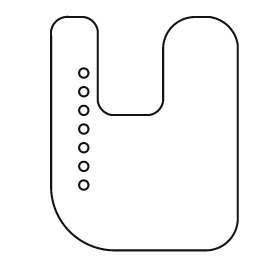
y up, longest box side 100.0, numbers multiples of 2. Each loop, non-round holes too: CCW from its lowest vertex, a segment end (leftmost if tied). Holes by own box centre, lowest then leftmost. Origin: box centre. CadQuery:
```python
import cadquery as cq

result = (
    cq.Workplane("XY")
    .moveTo(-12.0, -50.0)
    .lineTo(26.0, -50.0)
    .threePointArc((36.0, -46.0), (40.0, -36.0))
    .lineTo(40.0, 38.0)
    .threePointArc((36.0, 46.0), (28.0, 50.0))
    .lineTo(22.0, 50.0)
    .threePointArc((12.0, 46.0), (8.0, 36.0))
    .lineTo(8.0, 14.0)
    .threePointArc((6.0, 10.0), (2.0, 8.0))
    .lineTo(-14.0, 8.0)
    .threePointArc((-18.0, 10.0), (-20.0, 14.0))
    .lineTo(-20.0, 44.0)
    .threePointArc((-22.0, 48.0), (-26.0, 50.0))
    .lineTo(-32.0, 50.0)
    .threePointArc((-38.0, 48.0), (-40.0, 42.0))
    .lineTo(-40.0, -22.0)
    .threePointArc((-32.0, -42.0), (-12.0, -50.0))
    .close()
    .moveTo(-26.0, -22.0)
    .circle(2.0)
    .moveTo(-26.0, -14.0)
    .circle(2.0)
    .moveTo(-26.0, -6.0)
    .circle(2.0)
    .moveTo(-26.0, 2.0)
    .circle(2.0)
    .moveTo(-26.0, 10.0)
    .circle(2.0)
    .moveTo(-26.0, 18.0)
    .circle(2.0)
    .moveTo(-26.0, 26.0)
    .circle(2.0)
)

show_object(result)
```